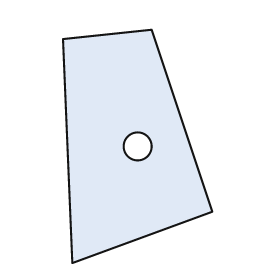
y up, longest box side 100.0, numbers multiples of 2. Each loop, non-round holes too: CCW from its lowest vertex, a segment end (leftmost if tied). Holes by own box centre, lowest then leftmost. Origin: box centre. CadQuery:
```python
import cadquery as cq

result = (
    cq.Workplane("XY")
    .moveTo(-28.0, -50.0)
    .lineTo(32.0, -28.0)
    .lineTo(6.0, 50.0)
    .lineTo(-32.0, 46.0)
    .close()
    .moveTo(0.0, 0.0)
    .circle(6.0)
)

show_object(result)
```